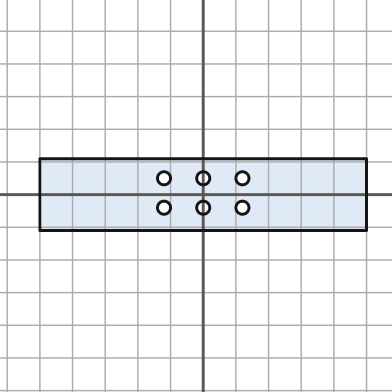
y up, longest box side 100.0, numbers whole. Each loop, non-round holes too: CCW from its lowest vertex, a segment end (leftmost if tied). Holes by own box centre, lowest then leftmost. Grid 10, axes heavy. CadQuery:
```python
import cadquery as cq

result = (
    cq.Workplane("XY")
    .moveTo(-50.0, -11.0)
    .lineTo(50.0, -11.0)
    .lineTo(50.0, 11.0)
    .lineTo(-50.0, 11.0)
    .close()
    .moveTo(-12.0, -4.0)
    .circle(2.0)
    .moveTo(0.0, -4.0)
    .circle(2.0)
    .moveTo(12.0, -4.0)
    .circle(2.0)
    .moveTo(-12.0, 5.0)
    .circle(2.0)
    .moveTo(0.0, 5.0)
    .circle(2.0)
    .moveTo(12.0, 5.0)
    .circle(2.0)
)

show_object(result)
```